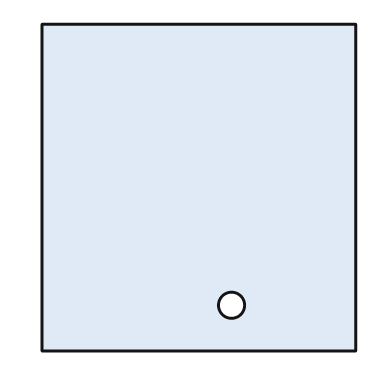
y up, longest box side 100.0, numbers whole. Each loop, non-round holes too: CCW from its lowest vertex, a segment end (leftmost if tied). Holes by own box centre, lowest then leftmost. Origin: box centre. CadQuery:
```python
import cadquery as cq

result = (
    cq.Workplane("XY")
    .moveTo(-48.0, -50.0)
    .lineTo(48.0, -50.0)
    .lineTo(48.0, 50.0)
    .lineTo(-48.0, 50.0)
    .close()
    .moveTo(10.0, -36.0)
    .circle(4.0)
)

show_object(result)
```